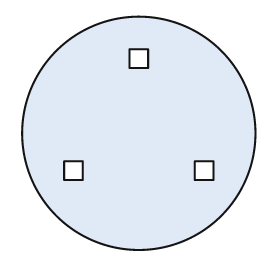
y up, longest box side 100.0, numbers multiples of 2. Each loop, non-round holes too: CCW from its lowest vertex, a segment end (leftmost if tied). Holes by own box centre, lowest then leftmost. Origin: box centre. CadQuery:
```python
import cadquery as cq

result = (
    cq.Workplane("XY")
    .moveTo(0.0, 0.0)
    .circle(50.0)
    .moveTo(-32.0, -20.0)
    .lineTo(-24.0, -20.0)
    .lineTo(-24.0, -12.0)
    .lineTo(-32.0, -12.0)
    .close()
    .moveTo(24.0, -20.0)
    .lineTo(32.0, -20.0)
    .lineTo(32.0, -12.0)
    .lineTo(24.0, -12.0)
    .close()
    .moveTo(-4.0, 28.0)
    .lineTo(4.0, 28.0)
    .lineTo(4.0, 36.0)
    .lineTo(-4.0, 36.0)
    .close()
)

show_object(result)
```